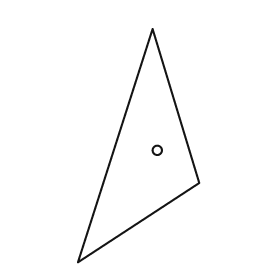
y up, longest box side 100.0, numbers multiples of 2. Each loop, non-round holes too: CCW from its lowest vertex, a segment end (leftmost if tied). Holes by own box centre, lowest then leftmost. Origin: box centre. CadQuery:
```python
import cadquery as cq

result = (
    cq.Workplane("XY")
    .moveTo(-26.0, -50.0)
    .lineTo(26.0, -16.0)
    .lineTo(6.0, 50.0)
    .close()
    .moveTo(8.0, -2.0)
    .circle(2.0)
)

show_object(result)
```